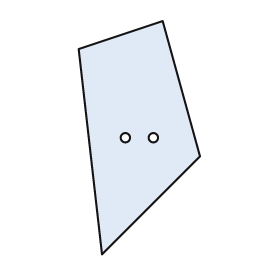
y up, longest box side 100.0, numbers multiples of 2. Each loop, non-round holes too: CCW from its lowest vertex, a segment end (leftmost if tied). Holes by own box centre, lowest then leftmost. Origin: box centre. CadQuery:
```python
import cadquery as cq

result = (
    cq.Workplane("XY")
    .moveTo(-16.0, -50.0)
    .lineTo(26.0, -8.0)
    .lineTo(10.0, 50.0)
    .lineTo(-26.0, 38.0)
    .close()
    .moveTo(-6.0, 0.0)
    .circle(2.0)
    .moveTo(6.0, 0.0)
    .circle(2.0)
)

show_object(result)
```